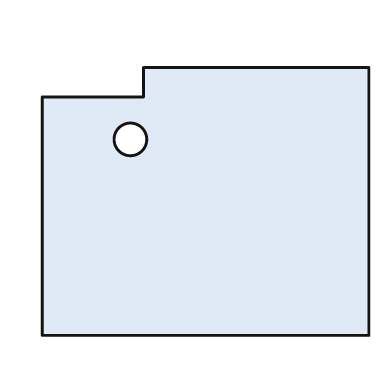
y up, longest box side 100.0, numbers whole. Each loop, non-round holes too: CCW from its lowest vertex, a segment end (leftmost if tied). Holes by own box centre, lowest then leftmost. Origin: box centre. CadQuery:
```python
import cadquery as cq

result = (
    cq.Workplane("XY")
    .moveTo(-50.0, -41.0)
    .lineTo(50.0, -41.0)
    .lineTo(50.0, 41.0)
    .lineTo(-19.0, 41.0)
    .lineTo(-19.0, 32.0)
    .lineTo(-50.0, 32.0)
    .close()
    .moveTo(-23.0, 19.0)
    .circle(5.0)
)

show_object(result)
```